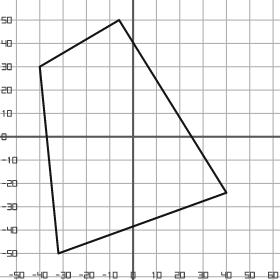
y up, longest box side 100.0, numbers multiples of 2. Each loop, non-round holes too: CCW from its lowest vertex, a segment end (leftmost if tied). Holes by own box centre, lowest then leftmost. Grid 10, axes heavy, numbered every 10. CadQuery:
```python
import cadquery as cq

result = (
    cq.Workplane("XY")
    .moveTo(-32.0, -50.0)
    .lineTo(40.0, -24.0)
    .lineTo(-6.0, 50.0)
    .lineTo(-40.0, 30.0)
    .close()
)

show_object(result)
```